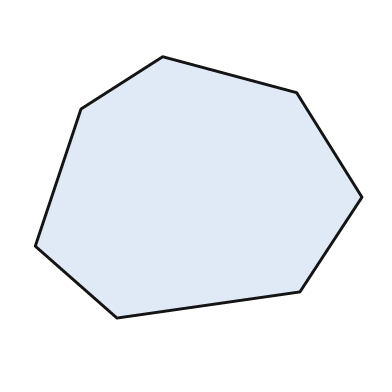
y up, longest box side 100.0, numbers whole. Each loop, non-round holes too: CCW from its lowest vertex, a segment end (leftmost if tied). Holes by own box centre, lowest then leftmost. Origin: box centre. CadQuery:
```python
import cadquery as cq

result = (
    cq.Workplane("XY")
    .moveTo(-25.0, -40.0)
    .lineTo(31.0, -32.0)
    .lineTo(50.0, -3.0)
    .lineTo(30.0, 29.0)
    .lineTo(-11.0, 40.0)
    .lineTo(-36.0, 24.0)
    .lineTo(-50.0, -18.0)
    .close()
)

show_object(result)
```